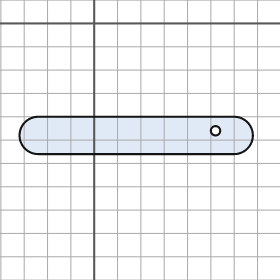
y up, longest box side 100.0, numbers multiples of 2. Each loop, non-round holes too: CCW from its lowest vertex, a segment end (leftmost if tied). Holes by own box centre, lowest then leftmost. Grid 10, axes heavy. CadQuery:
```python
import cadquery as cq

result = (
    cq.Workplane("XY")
    .moveTo(-24.0, -56.0)
    .lineTo(60.0, -56.0)
    .threePointArc((68.0, -48.0), (60.0, -40.0))
    .lineTo(-24.0, -40.0)
    .threePointArc((-32.0, -48.0), (-24.0, -56.0))
    .close()
    .moveTo(52.0, -46.0)
    .circle(2.0)
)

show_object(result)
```